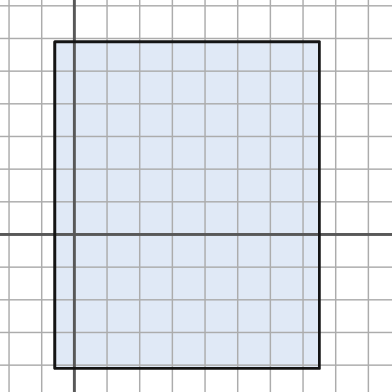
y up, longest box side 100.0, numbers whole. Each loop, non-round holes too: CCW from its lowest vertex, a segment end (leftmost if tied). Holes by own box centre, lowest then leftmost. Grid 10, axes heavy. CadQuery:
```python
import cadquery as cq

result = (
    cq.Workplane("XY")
    .moveTo(-6.0, -41.0)
    .lineTo(75.0, -41.0)
    .lineTo(75.0, 59.0)
    .lineTo(-6.0, 59.0)
    .close()
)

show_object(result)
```